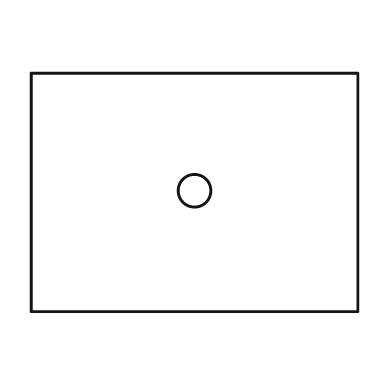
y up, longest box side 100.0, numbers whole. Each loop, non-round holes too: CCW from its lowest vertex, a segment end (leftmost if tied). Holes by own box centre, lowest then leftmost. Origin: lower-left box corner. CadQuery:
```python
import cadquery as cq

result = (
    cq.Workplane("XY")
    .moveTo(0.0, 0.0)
    .lineTo(100.0, 0.0)
    .lineTo(100.0, 73.0)
    .lineTo(0.0, 73.0)
    .close()
    .moveTo(50.0, 37.0)
    .circle(5.0)
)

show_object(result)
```